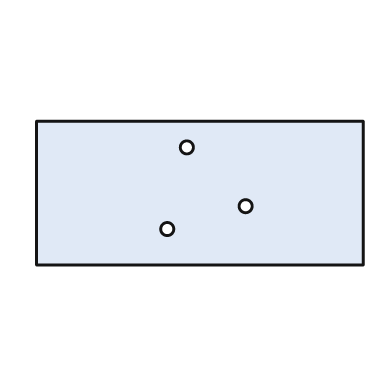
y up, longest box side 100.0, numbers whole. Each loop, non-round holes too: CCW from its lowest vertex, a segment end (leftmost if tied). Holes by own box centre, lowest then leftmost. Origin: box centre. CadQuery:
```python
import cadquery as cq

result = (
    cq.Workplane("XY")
    .moveTo(-50.0, -22.0)
    .lineTo(50.0, -22.0)
    .lineTo(50.0, 22.0)
    .lineTo(-50.0, 22.0)
    .close()
    .moveTo(-10.0, -11.0)
    .circle(2.0)
    .moveTo(14.0, -4.0)
    .circle(2.0)
    .moveTo(-4.0, 14.0)
    .circle(2.0)
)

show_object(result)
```